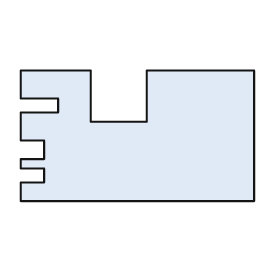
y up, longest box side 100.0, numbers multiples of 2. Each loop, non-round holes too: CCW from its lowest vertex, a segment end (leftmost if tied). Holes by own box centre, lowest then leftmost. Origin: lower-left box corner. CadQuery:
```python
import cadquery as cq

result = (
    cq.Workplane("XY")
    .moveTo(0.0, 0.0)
    .lineTo(100.0, 0.0)
    .lineTo(100.0, 56.0)
    .lineTo(54.0, 56.0)
    .lineTo(54.0, 34.0)
    .lineTo(30.0, 34.0)
    .lineTo(30.0, 56.0)
    .lineTo(0.0, 56.0)
    .lineTo(0.0, 44.0)
    .lineTo(16.0, 44.0)
    .lineTo(16.0, 38.0)
    .lineTo(0.0, 38.0)
    .lineTo(0.0, 26.0)
    .lineTo(10.0, 26.0)
    .lineTo(10.0, 18.0)
    .lineTo(0.0, 18.0)
    .lineTo(0.0, 14.0)
    .lineTo(10.0, 14.0)
    .lineTo(10.0, 8.0)
    .lineTo(0.0, 8.0)
    .close()
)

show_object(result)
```